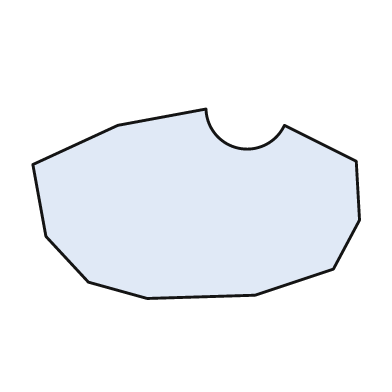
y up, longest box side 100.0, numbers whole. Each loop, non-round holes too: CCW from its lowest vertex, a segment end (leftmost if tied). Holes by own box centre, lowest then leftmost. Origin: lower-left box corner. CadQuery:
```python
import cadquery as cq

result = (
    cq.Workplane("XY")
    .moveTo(35.0, 0.0)
    .lineTo(68.0, 1.0)
    .lineTo(92.0, 9.0)
    .lineTo(100.0, 24.0)
    .lineTo(99.0, 42.0)
    .lineTo(77.0, 53.0)
    .threePointArc((63.0, 46.0), (53.0, 58.0))
    .lineTo(26.0, 53.0)
    .lineTo(0.0, 41.0)
    .lineTo(4.0, 19.0)
    .lineTo(17.0, 5.0)
    .close()
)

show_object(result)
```